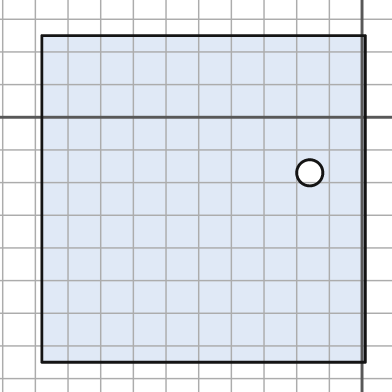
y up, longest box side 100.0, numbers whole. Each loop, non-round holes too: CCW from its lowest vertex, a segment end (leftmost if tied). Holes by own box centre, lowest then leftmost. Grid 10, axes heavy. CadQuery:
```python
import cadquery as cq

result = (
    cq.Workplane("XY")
    .moveTo(-98.0, -75.0)
    .lineTo(1.0, -75.0)
    .lineTo(1.0, 25.0)
    .lineTo(-98.0, 25.0)
    .close()
    .moveTo(-16.0, -17.0)
    .circle(4.0)
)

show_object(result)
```